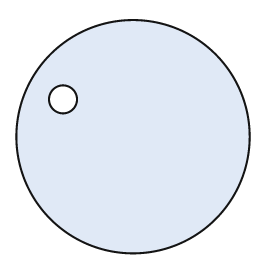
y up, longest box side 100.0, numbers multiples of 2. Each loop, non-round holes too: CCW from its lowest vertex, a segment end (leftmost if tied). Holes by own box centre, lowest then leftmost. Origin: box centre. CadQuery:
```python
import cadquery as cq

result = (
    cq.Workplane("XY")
    .moveTo(0.0, 0.0)
    .circle(50.0)
    .moveTo(-30.0, 16.0)
    .circle(6.0)
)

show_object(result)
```